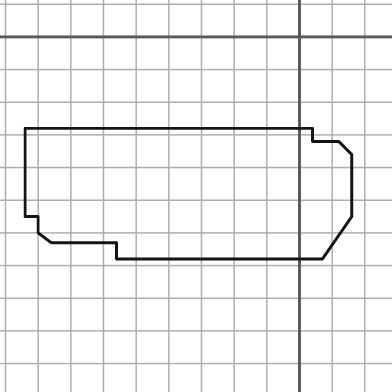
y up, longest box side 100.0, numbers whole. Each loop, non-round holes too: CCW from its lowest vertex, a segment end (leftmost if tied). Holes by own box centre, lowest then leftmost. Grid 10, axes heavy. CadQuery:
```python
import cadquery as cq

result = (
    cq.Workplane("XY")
    .moveTo(-56.0, -68.0)
    .lineTo(7.0, -68.0)
    .lineTo(16.0, -55.0)
    .lineTo(16.0, -36.0)
    .lineTo(12.0, -32.0)
    .lineTo(4.0, -32.0)
    .lineTo(4.0, -28.0)
    .lineTo(-84.0, -28.0)
    .lineTo(-84.0, -55.0)
    .lineTo(-80.0, -55.0)
    .lineTo(-80.0, -60.0)
    .lineTo(-76.0, -63.0)
    .lineTo(-56.0, -63.0)
    .close()
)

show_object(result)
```